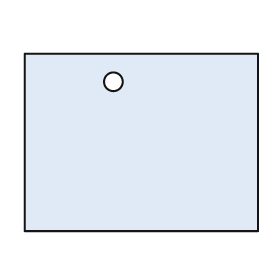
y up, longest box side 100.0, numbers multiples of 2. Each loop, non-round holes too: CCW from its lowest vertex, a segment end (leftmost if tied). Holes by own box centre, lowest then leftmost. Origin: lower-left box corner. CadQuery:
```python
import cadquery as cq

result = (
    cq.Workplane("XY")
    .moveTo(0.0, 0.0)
    .lineTo(100.0, 0.0)
    .lineTo(100.0, 76.0)
    .lineTo(0.0, 76.0)
    .close()
    .moveTo(38.0, 64.0)
    .circle(4.0)
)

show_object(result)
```